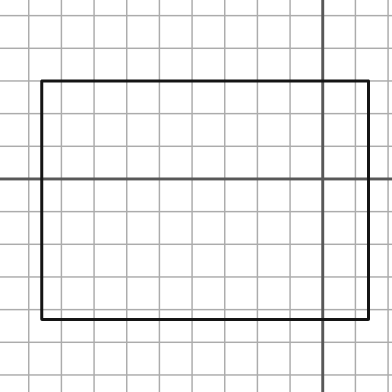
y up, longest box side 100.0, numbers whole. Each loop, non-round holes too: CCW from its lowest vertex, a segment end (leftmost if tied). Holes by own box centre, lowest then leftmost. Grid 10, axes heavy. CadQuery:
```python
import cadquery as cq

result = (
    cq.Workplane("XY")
    .moveTo(-86.0, -43.0)
    .lineTo(14.0, -43.0)
    .lineTo(14.0, 30.0)
    .lineTo(-86.0, 30.0)
    .close()
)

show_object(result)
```